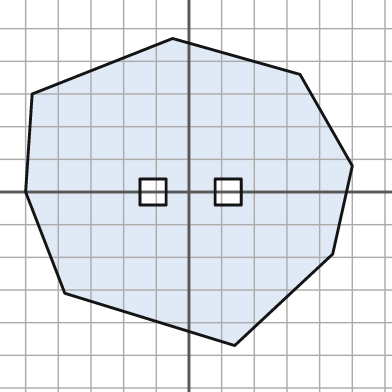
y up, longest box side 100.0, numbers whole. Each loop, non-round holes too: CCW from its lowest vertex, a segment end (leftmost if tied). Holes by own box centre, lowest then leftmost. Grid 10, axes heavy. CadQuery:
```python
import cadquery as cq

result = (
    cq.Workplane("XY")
    .moveTo(14.0, -47.0)
    .lineTo(44.0, -19.0)
    .lineTo(50.0, 8.0)
    .lineTo(34.0, 36.0)
    .lineTo(-5.0, 47.0)
    .lineTo(-48.0, 30.0)
    .lineTo(-50.0, 0.0)
    .lineTo(-38.0, -31.0)
    .close()
    .moveTo(-15.0, -4.0)
    .lineTo(-7.0, -4.0)
    .lineTo(-7.0, 4.0)
    .lineTo(-15.0, 4.0)
    .close()
    .moveTo(8.0, -4.0)
    .lineTo(16.0, -4.0)
    .lineTo(16.0, 4.0)
    .lineTo(8.0, 4.0)
    .close()
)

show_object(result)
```